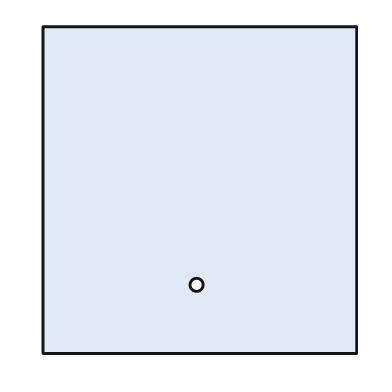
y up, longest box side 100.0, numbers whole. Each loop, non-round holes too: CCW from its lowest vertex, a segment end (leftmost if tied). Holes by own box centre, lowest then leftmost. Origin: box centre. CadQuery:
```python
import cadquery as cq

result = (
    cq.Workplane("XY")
    .moveTo(-48.0, -50.0)
    .lineTo(48.0, -50.0)
    .lineTo(48.0, 50.0)
    .lineTo(-48.0, 50.0)
    .close()
    .moveTo(-1.0, -29.0)
    .circle(2.0)
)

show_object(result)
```